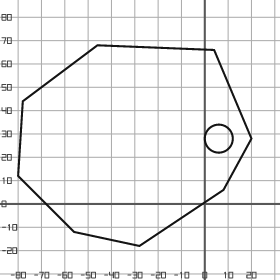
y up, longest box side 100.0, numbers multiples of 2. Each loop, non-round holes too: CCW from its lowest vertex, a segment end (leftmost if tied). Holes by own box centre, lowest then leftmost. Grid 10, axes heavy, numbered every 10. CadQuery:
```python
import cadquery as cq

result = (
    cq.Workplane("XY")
    .moveTo(-28.0, -18.0)
    .lineTo(8.0, 6.0)
    .lineTo(20.0, 28.0)
    .lineTo(4.0, 66.0)
    .lineTo(-46.0, 68.0)
    .lineTo(-78.0, 44.0)
    .lineTo(-80.0, 12.0)
    .lineTo(-56.0, -12.0)
    .close()
    .moveTo(6.0, 28.0)
    .circle(6.0)
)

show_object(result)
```